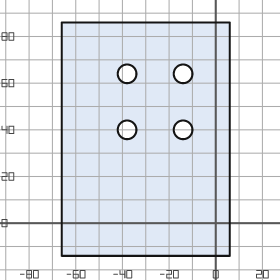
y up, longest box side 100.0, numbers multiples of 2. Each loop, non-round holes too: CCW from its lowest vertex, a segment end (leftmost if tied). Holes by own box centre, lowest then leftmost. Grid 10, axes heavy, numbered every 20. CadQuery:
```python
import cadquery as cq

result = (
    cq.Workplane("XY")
    .moveTo(-66.0, -14.0)
    .lineTo(6.0, -14.0)
    .lineTo(6.0, 86.0)
    .lineTo(-66.0, 86.0)
    .close()
    .moveTo(-38.0, 40.0)
    .circle(4.0)
    .moveTo(-14.0, 40.0)
    .circle(4.0)
    .moveTo(-38.0, 64.0)
    .circle(4.0)
    .moveTo(-14.0, 64.0)
    .circle(4.0)
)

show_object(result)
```